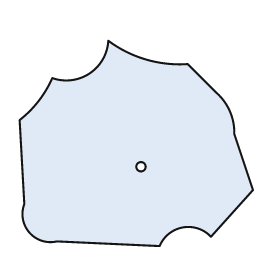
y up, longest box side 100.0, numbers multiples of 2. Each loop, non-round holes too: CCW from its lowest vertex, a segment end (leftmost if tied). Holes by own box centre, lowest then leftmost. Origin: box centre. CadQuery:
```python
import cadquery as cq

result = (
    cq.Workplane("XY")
    .moveTo(10.0, -44.0)
    .threePointArc((20.0, -36.0), (32.0, -40.0))
    .lineTo(50.0, -20.0)
    .lineTo(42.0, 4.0)
    .threePointArc((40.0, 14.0), (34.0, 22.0))
    .lineTo(22.0, 34.0)
    .threePointArc((4.0, 36.0), (-12.0, 44.0))
    .threePointArc((-20.0, 30.0), (-36.0, 28.0))
    .threePointArc((-42.0, 18.0), (-50.0, 10.0))
    .lineTo(-48.0, -26.0)
    .threePointArc((-46.0, -38.0), (-34.0, -42.0))
    .close()
    .moveTo(2.0, -10.0)
    .circle(2.0)
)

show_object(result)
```